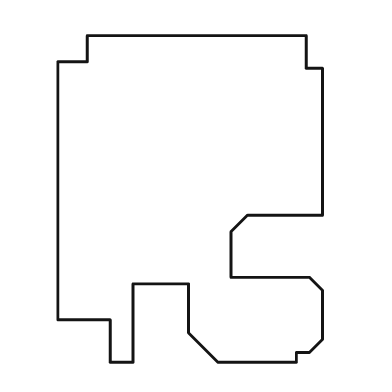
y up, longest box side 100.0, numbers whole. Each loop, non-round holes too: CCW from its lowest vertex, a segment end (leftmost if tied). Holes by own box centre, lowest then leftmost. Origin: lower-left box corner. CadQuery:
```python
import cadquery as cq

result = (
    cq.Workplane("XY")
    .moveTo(16.0, 0.0)
    .lineTo(23.0, 0.0)
    .lineTo(23.0, 24.0)
    .lineTo(40.0, 24.0)
    .lineTo(40.0, 9.0)
    .lineTo(49.0, 0.0)
    .lineTo(73.0, 0.0)
    .lineTo(73.0, 3.0)
    .lineTo(77.0, 3.0)
    .lineTo(81.0, 7.0)
    .lineTo(81.0, 22.0)
    .lineTo(77.0, 26.0)
    .lineTo(53.0, 26.0)
    .lineTo(53.0, 40.0)
    .lineTo(58.0, 45.0)
    .lineTo(81.0, 45.0)
    .lineTo(81.0, 90.0)
    .lineTo(76.0, 90.0)
    .lineTo(76.0, 100.0)
    .lineTo(9.0, 100.0)
    .lineTo(9.0, 92.0)
    .lineTo(0.0, 92.0)
    .lineTo(0.0, 13.0)
    .lineTo(16.0, 13.0)
    .close()
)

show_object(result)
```